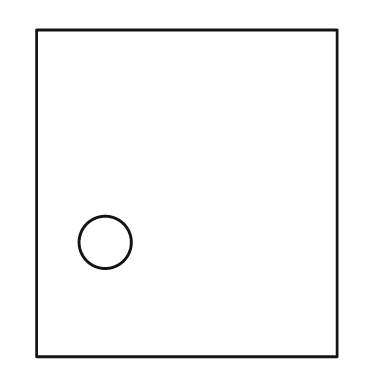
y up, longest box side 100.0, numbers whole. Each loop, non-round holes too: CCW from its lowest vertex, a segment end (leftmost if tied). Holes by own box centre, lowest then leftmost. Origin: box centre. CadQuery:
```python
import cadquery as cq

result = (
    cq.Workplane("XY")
    .moveTo(-46.0, -50.0)
    .lineTo(46.0, -50.0)
    .lineTo(46.0, 50.0)
    .lineTo(-46.0, 50.0)
    .close()
    .moveTo(-25.0, -15.0)
    .circle(8.0)
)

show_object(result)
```